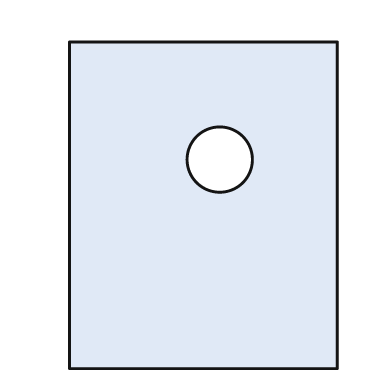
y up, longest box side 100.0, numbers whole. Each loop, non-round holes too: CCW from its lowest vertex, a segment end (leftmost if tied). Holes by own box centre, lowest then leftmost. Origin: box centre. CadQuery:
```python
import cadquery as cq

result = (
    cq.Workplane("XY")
    .moveTo(-41.0, -50.0)
    .lineTo(41.0, -50.0)
    .lineTo(41.0, 50.0)
    .lineTo(-41.0, 50.0)
    .close()
    .moveTo(5.0, 14.0)
    .circle(10.0)
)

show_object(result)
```